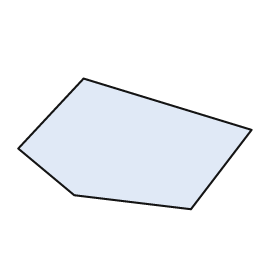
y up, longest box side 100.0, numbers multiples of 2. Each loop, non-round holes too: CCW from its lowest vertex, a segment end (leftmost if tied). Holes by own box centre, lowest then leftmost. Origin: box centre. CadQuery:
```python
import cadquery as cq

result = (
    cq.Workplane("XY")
    .moveTo(24.0, -28.0)
    .lineTo(50.0, 6.0)
    .lineTo(-22.0, 28.0)
    .lineTo(-50.0, -2.0)
    .lineTo(-26.0, -22.0)
    .close()
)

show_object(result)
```